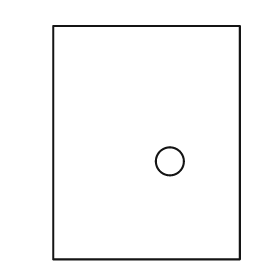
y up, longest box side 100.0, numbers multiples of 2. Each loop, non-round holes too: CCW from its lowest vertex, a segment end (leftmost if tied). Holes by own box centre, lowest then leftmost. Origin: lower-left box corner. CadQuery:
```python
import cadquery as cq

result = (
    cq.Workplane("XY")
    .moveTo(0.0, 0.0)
    .lineTo(80.0, 0.0)
    .lineTo(80.0, 100.0)
    .lineTo(0.0, 100.0)
    .close()
    .moveTo(50.0, 42.0)
    .circle(6.0)
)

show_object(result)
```